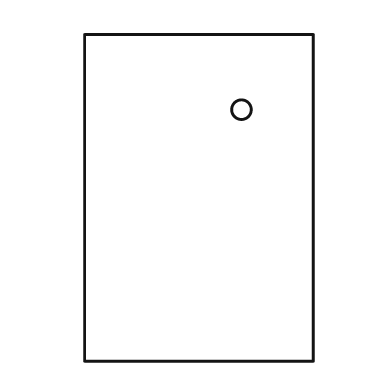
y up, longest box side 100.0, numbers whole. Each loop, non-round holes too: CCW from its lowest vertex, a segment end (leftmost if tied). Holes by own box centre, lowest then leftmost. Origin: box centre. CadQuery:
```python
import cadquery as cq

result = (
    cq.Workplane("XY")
    .moveTo(-35.0, -50.0)
    .lineTo(35.0, -50.0)
    .lineTo(35.0, 50.0)
    .lineTo(-35.0, 50.0)
    .close()
    .moveTo(13.0, 27.0)
    .circle(3.0)
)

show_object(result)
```